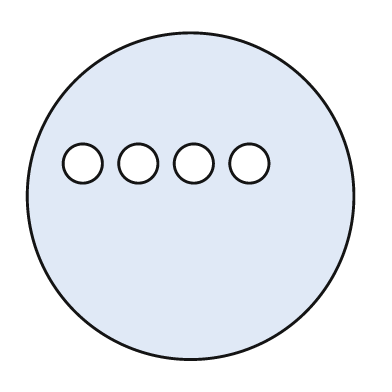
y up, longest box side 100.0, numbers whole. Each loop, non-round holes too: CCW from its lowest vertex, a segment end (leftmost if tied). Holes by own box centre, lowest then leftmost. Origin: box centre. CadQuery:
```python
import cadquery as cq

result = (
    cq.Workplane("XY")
    .moveTo(0.0, 0.0)
    .circle(50.0)
    .moveTo(-33.0, 10.0)
    .circle(6.0)
    .moveTo(-16.0, 10.0)
    .circle(6.0)
    .moveTo(1.0, 10.0)
    .circle(6.0)
    .moveTo(18.0, 10.0)
    .circle(6.0)
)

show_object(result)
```